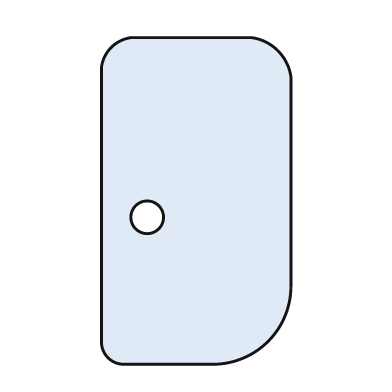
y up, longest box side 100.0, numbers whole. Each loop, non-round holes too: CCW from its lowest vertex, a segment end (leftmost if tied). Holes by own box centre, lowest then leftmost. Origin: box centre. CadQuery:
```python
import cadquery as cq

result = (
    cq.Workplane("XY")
    .moveTo(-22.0, -50.0)
    .lineTo(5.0, -50.0)
    .threePointArc((22.0, -43.0), (29.0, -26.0))
    .lineTo(29.0, 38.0)
    .threePointArc((25.0, 46.0), (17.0, 50.0))
    .lineTo(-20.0, 50.0)
    .threePointArc((-26.0, 47.0), (-29.0, 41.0))
    .lineTo(-29.0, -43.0)
    .threePointArc((-27.0, -48.0), (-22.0, -50.0))
    .close()
    .moveTo(-15.0, -5.0)
    .circle(5.0)
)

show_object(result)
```